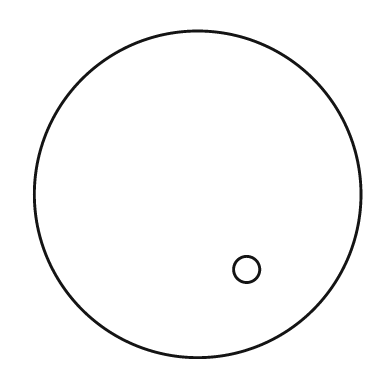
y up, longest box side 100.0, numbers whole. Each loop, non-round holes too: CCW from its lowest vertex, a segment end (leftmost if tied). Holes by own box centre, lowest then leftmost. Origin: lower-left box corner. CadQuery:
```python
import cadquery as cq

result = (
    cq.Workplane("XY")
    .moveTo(50.0, 50.0)
    .circle(50.0)
    .moveTo(65.0, 27.0)
    .circle(4.0)
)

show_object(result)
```